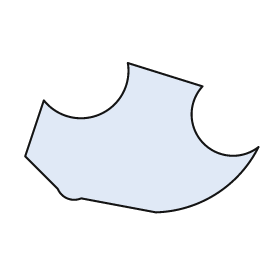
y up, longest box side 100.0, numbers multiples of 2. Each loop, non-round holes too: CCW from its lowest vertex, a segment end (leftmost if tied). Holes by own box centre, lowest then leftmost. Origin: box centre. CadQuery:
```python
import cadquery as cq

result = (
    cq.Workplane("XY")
    .moveTo(6.0, -32.0)
    .threePointArc((32.0, -24.0), (50.0, -4.0))
    .threePointArc((26.0, -2.0), (26.0, 22.0))
    .lineTo(-6.0, 32.0)
    .threePointArc((-18.0, 10.0), (-42.0, 16.0))
    .lineTo(-50.0, -8.0)
    .lineTo(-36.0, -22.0)
    .threePointArc((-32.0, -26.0), (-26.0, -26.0))
    .close()
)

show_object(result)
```